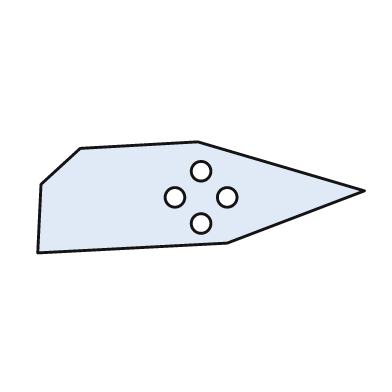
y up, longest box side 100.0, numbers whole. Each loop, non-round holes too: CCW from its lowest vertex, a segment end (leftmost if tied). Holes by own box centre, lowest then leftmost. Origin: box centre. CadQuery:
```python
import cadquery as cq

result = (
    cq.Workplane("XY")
    .moveTo(-50.0, -17.0)
    .lineTo(8.0, -14.0)
    .lineTo(50.0, 2.0)
    .lineTo(-1.0, 17.0)
    .lineTo(-37.0, 15.0)
    .lineTo(-49.0, 4.0)
    .close()
    .moveTo(0.0, -8.0)
    .circle(3.0)
    .moveTo(-8.0, 0.0)
    .circle(3.0)
    .moveTo(8.0, 0.0)
    .circle(3.0)
    .moveTo(0.0, 8.0)
    .circle(3.0)
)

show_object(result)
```